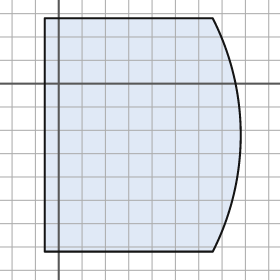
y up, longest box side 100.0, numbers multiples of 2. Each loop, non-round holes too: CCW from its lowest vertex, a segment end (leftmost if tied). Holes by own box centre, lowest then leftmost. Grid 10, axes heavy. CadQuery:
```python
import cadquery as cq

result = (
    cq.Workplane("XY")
    .moveTo(-6.0, -72.0)
    .lineTo(66.0, -72.0)
    .threePointArc((78.0, -22.0), (66.0, 28.0))
    .lineTo(-6.0, 28.0)
    .close()
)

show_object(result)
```